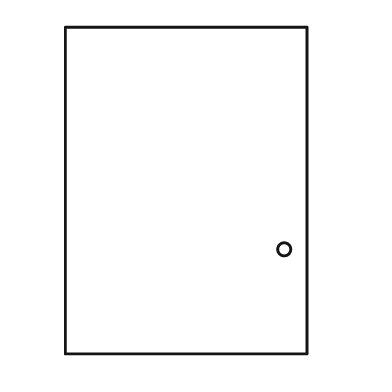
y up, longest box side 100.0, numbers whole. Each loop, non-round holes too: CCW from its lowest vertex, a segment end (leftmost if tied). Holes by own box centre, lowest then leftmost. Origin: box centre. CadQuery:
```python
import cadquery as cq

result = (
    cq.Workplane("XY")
    .moveTo(-37.0, -50.0)
    .lineTo(37.0, -50.0)
    .lineTo(37.0, 50.0)
    .lineTo(-37.0, 50.0)
    .close()
    .moveTo(30.0, -18.0)
    .circle(2.0)
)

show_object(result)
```